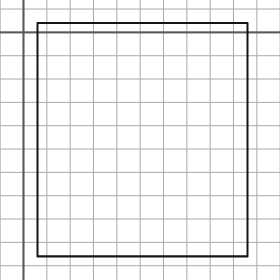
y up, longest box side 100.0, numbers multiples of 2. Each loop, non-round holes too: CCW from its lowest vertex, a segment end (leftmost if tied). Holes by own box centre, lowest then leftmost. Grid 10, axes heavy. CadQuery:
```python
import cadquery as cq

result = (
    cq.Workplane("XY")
    .moveTo(6.0, -96.0)
    .lineTo(96.0, -96.0)
    .lineTo(96.0, 4.0)
    .lineTo(6.0, 4.0)
    .close()
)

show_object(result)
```